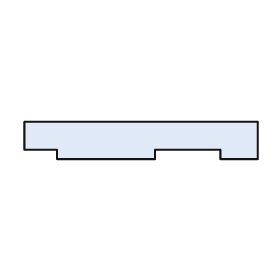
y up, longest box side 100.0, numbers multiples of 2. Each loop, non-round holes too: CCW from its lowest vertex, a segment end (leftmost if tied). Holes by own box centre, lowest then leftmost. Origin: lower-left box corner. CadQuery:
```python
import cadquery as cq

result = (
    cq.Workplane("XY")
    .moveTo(14.0, 0.0)
    .lineTo(56.0, 0.0)
    .lineTo(56.0, 4.0)
    .lineTo(84.0, 4.0)
    .lineTo(84.0, 0.0)
    .lineTo(100.0, 0.0)
    .lineTo(100.0, 16.0)
    .lineTo(0.0, 16.0)
    .lineTo(0.0, 4.0)
    .lineTo(14.0, 4.0)
    .close()
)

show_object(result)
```